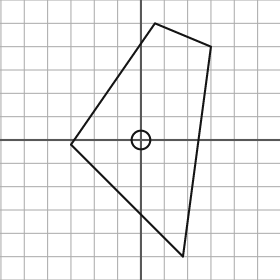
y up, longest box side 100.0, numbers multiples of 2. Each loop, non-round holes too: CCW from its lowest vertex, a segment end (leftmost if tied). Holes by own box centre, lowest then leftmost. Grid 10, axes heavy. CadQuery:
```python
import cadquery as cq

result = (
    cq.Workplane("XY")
    .moveTo(18.0, -50.0)
    .lineTo(30.0, 40.0)
    .lineTo(6.0, 50.0)
    .lineTo(-30.0, -2.0)
    .close()
    .moveTo(0.0, 0.0)
    .circle(4.0)
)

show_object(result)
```